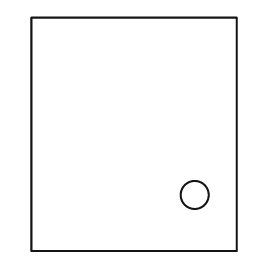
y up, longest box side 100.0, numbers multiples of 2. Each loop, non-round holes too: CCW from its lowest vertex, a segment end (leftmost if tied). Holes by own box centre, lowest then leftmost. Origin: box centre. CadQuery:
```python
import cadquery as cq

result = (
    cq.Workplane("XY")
    .moveTo(-44.0, -50.0)
    .lineTo(44.0, -50.0)
    .lineTo(44.0, 50.0)
    .lineTo(-44.0, 50.0)
    .close()
    .moveTo(26.0, -26.0)
    .circle(6.0)
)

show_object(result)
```